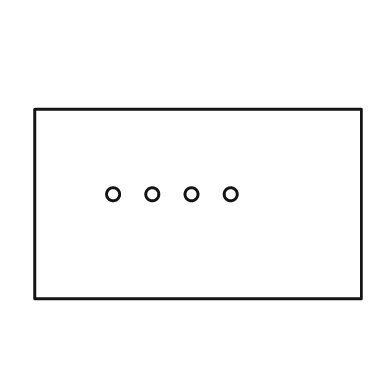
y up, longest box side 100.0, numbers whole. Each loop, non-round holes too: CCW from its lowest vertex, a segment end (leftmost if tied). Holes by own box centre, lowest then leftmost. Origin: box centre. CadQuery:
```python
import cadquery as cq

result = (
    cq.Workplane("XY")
    .moveTo(-50.0, -29.0)
    .lineTo(50.0, -29.0)
    .lineTo(50.0, 29.0)
    .lineTo(-50.0, 29.0)
    .close()
    .moveTo(-26.0, 3.0)
    .circle(2.0)
    .moveTo(-14.0, 3.0)
    .circle(2.0)
    .moveTo(-2.0, 3.0)
    .circle(2.0)
    .moveTo(10.0, 3.0)
    .circle(2.0)
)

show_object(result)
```